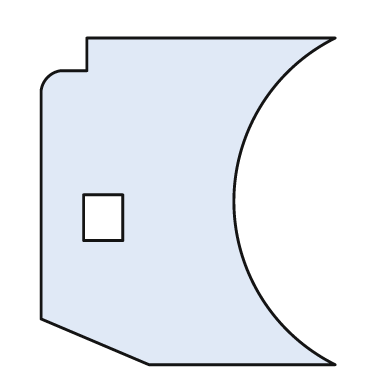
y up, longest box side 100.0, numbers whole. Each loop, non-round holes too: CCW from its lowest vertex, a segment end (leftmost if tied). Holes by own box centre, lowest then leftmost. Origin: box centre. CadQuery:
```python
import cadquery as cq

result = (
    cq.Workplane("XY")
    .moveTo(-12.0, -50.0)
    .lineTo(45.0, -50.0)
    .threePointArc((14.0, 0.0), (45.0, 50.0))
    .lineTo(-31.0, 50.0)
    .lineTo(-31.0, 40.0)
    .lineTo(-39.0, 40.0)
    .threePointArc((-43.0, 38.0), (-45.0, 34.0))
    .lineTo(-45.0, -36.0)
    .close()
    .moveTo(-32.0, -12.0)
    .lineTo(-20.0, -12.0)
    .lineTo(-20.0, 2.0)
    .lineTo(-32.0, 2.0)
    .close()
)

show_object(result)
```